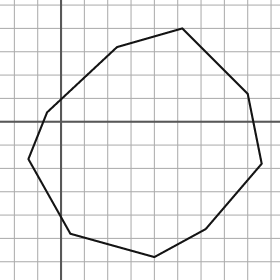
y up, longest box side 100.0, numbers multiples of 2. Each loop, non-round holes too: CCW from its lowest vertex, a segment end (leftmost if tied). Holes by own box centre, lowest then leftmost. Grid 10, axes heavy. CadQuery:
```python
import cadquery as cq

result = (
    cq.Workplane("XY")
    .moveTo(40.0, -58.0)
    .lineTo(62.0, -46.0)
    .lineTo(86.0, -18.0)
    .lineTo(80.0, 12.0)
    .lineTo(52.0, 40.0)
    .lineTo(24.0, 32.0)
    .lineTo(-6.0, 4.0)
    .lineTo(-14.0, -16.0)
    .lineTo(4.0, -48.0)
    .close()
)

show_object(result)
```